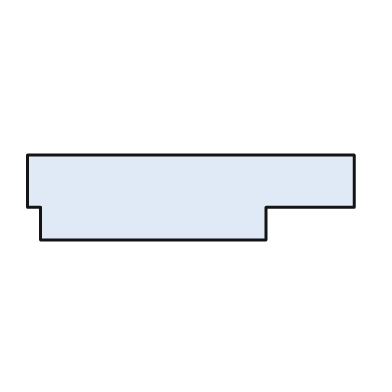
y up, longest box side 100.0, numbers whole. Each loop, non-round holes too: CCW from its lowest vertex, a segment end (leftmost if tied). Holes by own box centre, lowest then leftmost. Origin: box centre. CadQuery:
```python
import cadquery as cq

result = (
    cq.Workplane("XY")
    .moveTo(-46.0, -13.0)
    .lineTo(23.0, -13.0)
    .lineTo(23.0, -3.0)
    .lineTo(50.0, -3.0)
    .lineTo(50.0, 13.0)
    .lineTo(-50.0, 13.0)
    .lineTo(-50.0, -3.0)
    .lineTo(-46.0, -3.0)
    .close()
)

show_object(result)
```